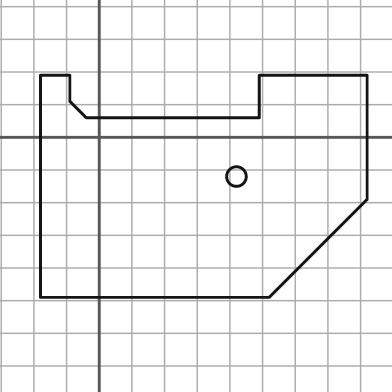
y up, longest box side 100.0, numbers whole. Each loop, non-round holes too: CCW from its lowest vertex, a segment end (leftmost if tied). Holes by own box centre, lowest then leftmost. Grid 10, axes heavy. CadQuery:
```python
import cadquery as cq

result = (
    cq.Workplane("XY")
    .moveTo(-18.0, -49.0)
    .lineTo(52.0, -49.0)
    .lineTo(82.0, -19.0)
    .lineTo(82.0, 19.0)
    .lineTo(49.0, 19.0)
    .lineTo(49.0, 6.0)
    .lineTo(-4.0, 6.0)
    .lineTo(-9.0, 11.0)
    .lineTo(-9.0, 19.0)
    .lineTo(-18.0, 19.0)
    .close()
    .moveTo(42.0, -12.0)
    .circle(3.0)
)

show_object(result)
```